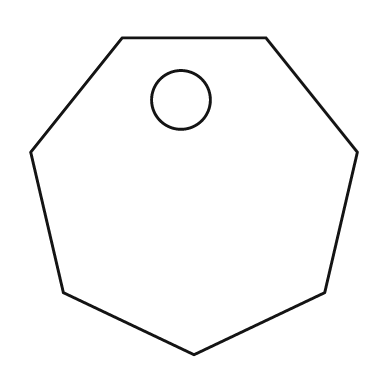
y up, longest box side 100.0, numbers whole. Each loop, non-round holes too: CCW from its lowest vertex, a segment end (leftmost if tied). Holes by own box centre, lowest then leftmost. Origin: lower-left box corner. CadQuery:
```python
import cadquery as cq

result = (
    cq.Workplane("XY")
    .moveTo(50.0, 0.0)
    .lineTo(90.0, 19.0)
    .lineTo(100.0, 62.0)
    .lineTo(72.0, 97.0)
    .lineTo(28.0, 97.0)
    .lineTo(0.0, 62.0)
    .lineTo(10.0, 19.0)
    .close()
    .moveTo(46.0, 78.0)
    .circle(9.0)
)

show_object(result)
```